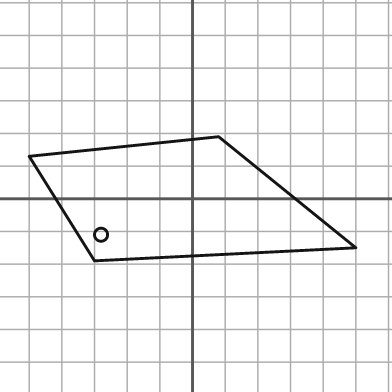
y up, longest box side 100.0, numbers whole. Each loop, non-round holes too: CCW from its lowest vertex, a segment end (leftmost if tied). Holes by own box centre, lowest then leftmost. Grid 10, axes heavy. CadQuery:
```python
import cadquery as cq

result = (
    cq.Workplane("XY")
    .moveTo(-30.0, -19.0)
    .lineTo(50.0, -15.0)
    .lineTo(8.0, 19.0)
    .lineTo(-50.0, 13.0)
    .close()
    .moveTo(-28.0, -11.0)
    .circle(2.0)
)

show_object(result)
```